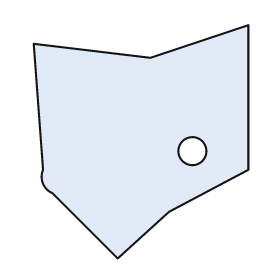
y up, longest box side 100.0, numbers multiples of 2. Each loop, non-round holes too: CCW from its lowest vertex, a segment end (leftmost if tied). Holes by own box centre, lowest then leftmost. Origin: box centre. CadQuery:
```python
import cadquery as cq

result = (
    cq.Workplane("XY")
    .moveTo(-10.0, -50.0)
    .lineTo(12.0, -30.0)
    .lineTo(46.0, -12.0)
    .lineTo(46.0, 50.0)
    .lineTo(4.0, 36.0)
    .lineTo(-46.0, 42.0)
    .lineTo(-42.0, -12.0)
    .threePointArc((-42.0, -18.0), (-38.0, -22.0))
    .close()
    .moveTo(22.0, -4.0)
    .circle(6.0)
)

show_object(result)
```